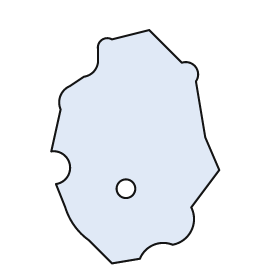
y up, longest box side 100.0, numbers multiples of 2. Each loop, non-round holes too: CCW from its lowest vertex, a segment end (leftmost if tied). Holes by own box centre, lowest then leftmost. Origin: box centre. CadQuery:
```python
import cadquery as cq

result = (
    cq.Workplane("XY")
    .moveTo(-10.0, -50.0)
    .lineTo(2.0, -48.0)
    .threePointArc((8.0, -42.0), (16.0, -42.0))
    .threePointArc((24.0, -36.0), (24.0, -26.0))
    .lineTo(36.0, -10.0)
    .lineTo(30.0, 4.0)
    .lineTo(26.0, 28.0)
    .threePointArc((26.0, 34.0), (20.0, 36.0))
    .lineTo(6.0, 50.0)
    .lineTo(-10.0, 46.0)
    .threePointArc((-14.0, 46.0), (-16.0, 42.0))
    .lineTo(-16.0, 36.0)
    .threePointArc((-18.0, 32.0), (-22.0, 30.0))
    .lineTo(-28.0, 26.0)
    .threePointArc((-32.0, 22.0), (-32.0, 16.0))
    .lineTo(-36.0, -2.0)
    .threePointArc((-28.0, -8.0), (-34.0, -16.0))
    .lineTo(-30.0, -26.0)
    .threePointArc((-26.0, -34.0), (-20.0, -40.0))
    .close()
    .moveTo(-4.0, -18.0)
    .circle(4.0)
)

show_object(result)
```